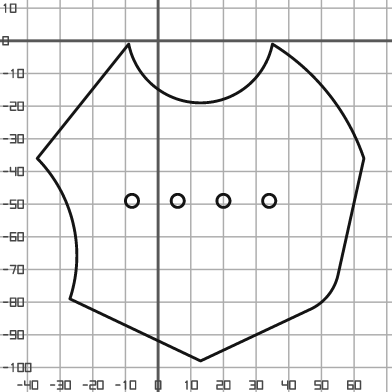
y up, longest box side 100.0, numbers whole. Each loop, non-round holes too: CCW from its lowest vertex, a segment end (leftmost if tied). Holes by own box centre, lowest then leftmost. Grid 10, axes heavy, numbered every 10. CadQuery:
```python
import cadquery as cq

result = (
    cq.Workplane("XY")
    .moveTo(13.0, -98.0)
    .lineTo(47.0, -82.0)
    .threePointArc((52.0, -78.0), (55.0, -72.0))
    .lineTo(63.0, -36.0)
    .threePointArc((52.0, -16.0), (35.0, -1.0))
    .threePointArc((13.0, -19.0), (-9.0, -1.0))
    .lineTo(-37.0, -36.0)
    .threePointArc((-26.0, -56.0), (-27.0, -79.0))
    .close()
    .moveTo(-8.0, -49.0)
    .circle(2.0)
    .moveTo(6.0, -49.0)
    .circle(2.0)
    .moveTo(20.0, -49.0)
    .circle(2.0)
    .moveTo(34.0, -49.0)
    .circle(2.0)
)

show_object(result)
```